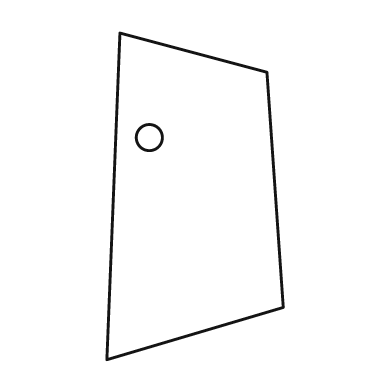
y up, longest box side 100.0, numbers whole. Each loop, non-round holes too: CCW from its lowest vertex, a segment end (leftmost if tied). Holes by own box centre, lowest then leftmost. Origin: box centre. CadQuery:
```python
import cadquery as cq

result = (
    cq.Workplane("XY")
    .moveTo(-27.0, -50.0)
    .lineTo(27.0, -34.0)
    .lineTo(22.0, 38.0)
    .lineTo(-23.0, 50.0)
    .close()
    .moveTo(-14.0, 18.0)
    .circle(4.0)
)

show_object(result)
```